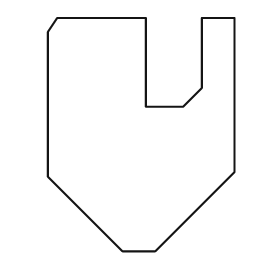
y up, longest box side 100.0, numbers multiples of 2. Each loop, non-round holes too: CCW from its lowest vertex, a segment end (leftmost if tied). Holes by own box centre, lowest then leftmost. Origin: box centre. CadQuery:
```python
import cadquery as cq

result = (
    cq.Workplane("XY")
    .moveTo(-8.0, -50.0)
    .lineTo(6.0, -50.0)
    .lineTo(40.0, -16.0)
    .lineTo(40.0, 50.0)
    .lineTo(26.0, 50.0)
    .lineTo(26.0, 20.0)
    .lineTo(18.0, 12.0)
    .lineTo(2.0, 12.0)
    .lineTo(2.0, 50.0)
    .lineTo(-36.0, 50.0)
    .lineTo(-40.0, 44.0)
    .lineTo(-40.0, -18.0)
    .close()
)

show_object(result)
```